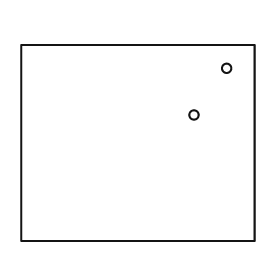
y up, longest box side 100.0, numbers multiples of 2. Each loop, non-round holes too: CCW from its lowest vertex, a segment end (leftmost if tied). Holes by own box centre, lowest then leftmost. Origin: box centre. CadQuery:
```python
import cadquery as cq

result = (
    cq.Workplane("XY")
    .moveTo(-50.0, -42.0)
    .lineTo(50.0, -42.0)
    .lineTo(50.0, 42.0)
    .lineTo(-50.0, 42.0)
    .close()
    .moveTo(24.0, 12.0)
    .circle(2.0)
    .moveTo(38.0, 32.0)
    .circle(2.0)
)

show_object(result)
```